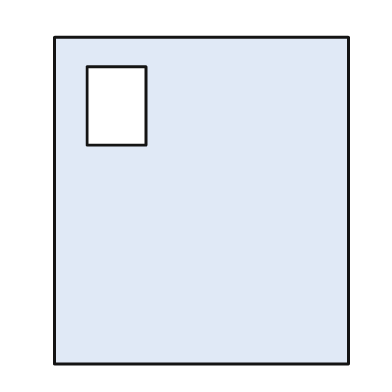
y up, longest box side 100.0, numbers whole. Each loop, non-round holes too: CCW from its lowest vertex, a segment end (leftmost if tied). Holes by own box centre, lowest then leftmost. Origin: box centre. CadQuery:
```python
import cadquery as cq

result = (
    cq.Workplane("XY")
    .moveTo(-45.0, -50.0)
    .lineTo(45.0, -50.0)
    .lineTo(45.0, 50.0)
    .lineTo(-45.0, 50.0)
    .close()
    .moveTo(-35.0, 17.0)
    .lineTo(-17.0, 17.0)
    .lineTo(-17.0, 41.0)
    .lineTo(-35.0, 41.0)
    .close()
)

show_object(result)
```